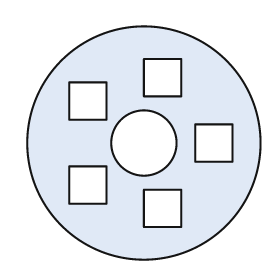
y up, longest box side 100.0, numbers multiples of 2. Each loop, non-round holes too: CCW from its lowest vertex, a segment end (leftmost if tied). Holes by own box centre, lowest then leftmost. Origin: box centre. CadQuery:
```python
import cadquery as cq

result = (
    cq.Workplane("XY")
    .moveTo(0.0, 0.0)
    .circle(50.0)
    .moveTo(0.0, -36.0)
    .lineTo(16.0, -36.0)
    .lineTo(16.0, -20.0)
    .lineTo(0.0, -20.0)
    .close()
    .moveTo(-32.0, -26.0)
    .lineTo(-16.0, -26.0)
    .lineTo(-16.0, -10.0)
    .lineTo(-32.0, -10.0)
    .close()
    .moveTo(0.0, 0.0)
    .circle(14.0)
    .moveTo(22.0, -8.0)
    .lineTo(38.0, -8.0)
    .lineTo(38.0, 8.0)
    .lineTo(22.0, 8.0)
    .close()
    .moveTo(-32.0, 10.0)
    .lineTo(-16.0, 10.0)
    .lineTo(-16.0, 26.0)
    .lineTo(-32.0, 26.0)
    .close()
    .moveTo(0.0, 20.0)
    .lineTo(16.0, 20.0)
    .lineTo(16.0, 36.0)
    .lineTo(0.0, 36.0)
    .close()
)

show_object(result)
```